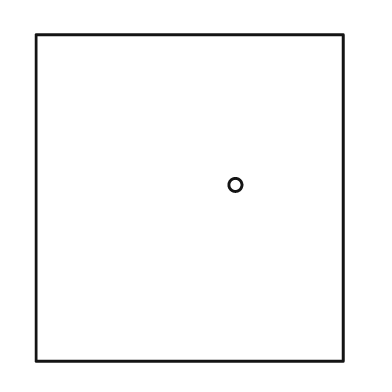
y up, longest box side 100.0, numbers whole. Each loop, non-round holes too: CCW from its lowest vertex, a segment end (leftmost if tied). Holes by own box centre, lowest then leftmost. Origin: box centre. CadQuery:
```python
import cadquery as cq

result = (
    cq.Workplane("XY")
    .moveTo(-47.0, -50.0)
    .lineTo(47.0, -50.0)
    .lineTo(47.0, 50.0)
    .lineTo(-47.0, 50.0)
    .close()
    .moveTo(14.0, 4.0)
    .circle(2.0)
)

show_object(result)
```